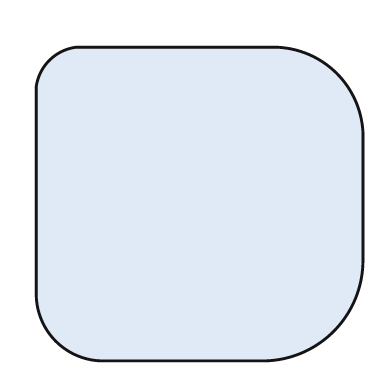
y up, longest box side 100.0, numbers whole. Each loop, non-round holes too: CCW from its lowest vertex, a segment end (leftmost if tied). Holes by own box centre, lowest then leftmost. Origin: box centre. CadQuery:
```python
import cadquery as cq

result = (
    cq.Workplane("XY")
    .moveTo(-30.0, -48.0)
    .lineTo(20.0, -48.0)
    .threePointArc((41.0, -39.0), (50.0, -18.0))
    .lineTo(50.0, 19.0)
    .threePointArc((42.0, 40.0), (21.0, 48.0))
    .lineTo(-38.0, 48.0)
    .threePointArc((-46.0, 44.0), (-50.0, 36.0))
    .lineTo(-50.0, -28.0)
    .threePointArc((-44.0, -42.0), (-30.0, -48.0))
    .close()
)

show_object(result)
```